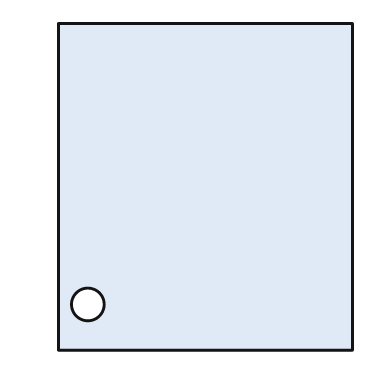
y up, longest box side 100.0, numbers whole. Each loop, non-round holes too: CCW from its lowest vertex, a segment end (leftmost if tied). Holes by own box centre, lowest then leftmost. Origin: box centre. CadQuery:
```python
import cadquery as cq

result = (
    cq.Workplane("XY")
    .moveTo(-45.0, -50.0)
    .lineTo(45.0, -50.0)
    .lineTo(45.0, 50.0)
    .lineTo(-45.0, 50.0)
    .close()
    .moveTo(-36.0, -36.0)
    .circle(5.0)
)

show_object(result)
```